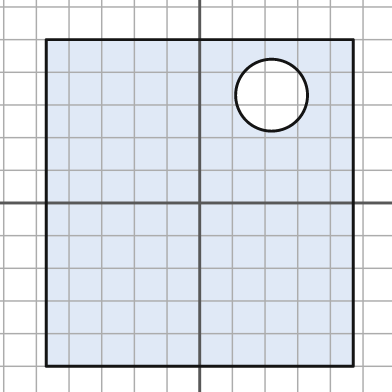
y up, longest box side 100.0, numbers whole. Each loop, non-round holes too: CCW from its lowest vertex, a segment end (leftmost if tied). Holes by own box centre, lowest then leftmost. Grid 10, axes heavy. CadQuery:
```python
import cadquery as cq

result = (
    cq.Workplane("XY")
    .moveTo(-47.0, -50.0)
    .lineTo(47.0, -50.0)
    .lineTo(47.0, 50.0)
    .lineTo(-47.0, 50.0)
    .close()
    .moveTo(22.0, 33.0)
    .circle(11.0)
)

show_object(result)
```